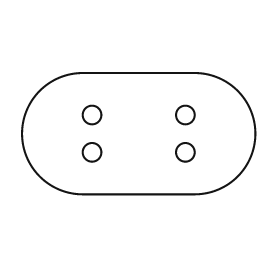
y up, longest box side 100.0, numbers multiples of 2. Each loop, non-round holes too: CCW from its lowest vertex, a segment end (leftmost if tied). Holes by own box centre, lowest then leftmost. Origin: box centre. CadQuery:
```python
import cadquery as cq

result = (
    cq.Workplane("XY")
    .moveTo(-24.0, -26.0)
    .lineTo(24.0, -26.0)
    .threePointArc((50.0, 0.0), (24.0, 26.0))
    .lineTo(-24.0, 26.0)
    .threePointArc((-50.0, 0.0), (-24.0, -26.0))
    .close()
    .moveTo(-20.0, -8.0)
    .circle(4.0)
    .moveTo(20.0, -8.0)
    .circle(4.0)
    .moveTo(-20.0, 8.0)
    .circle(4.0)
    .moveTo(20.0, 8.0)
    .circle(4.0)
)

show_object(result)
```